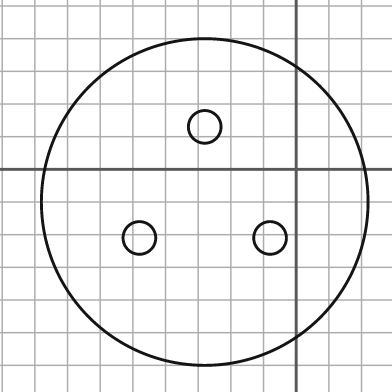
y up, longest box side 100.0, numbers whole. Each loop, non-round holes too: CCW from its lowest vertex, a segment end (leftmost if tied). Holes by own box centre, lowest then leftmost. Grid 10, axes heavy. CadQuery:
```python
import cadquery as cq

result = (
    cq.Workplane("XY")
    .moveTo(-28.0, -10.0)
    .circle(50.0)
    .moveTo(-48.0, -21.0)
    .circle(5.0)
    .moveTo(-8.0, -21.0)
    .circle(5.0)
    .moveTo(-28.0, 13.0)
    .circle(5.0)
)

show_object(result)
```